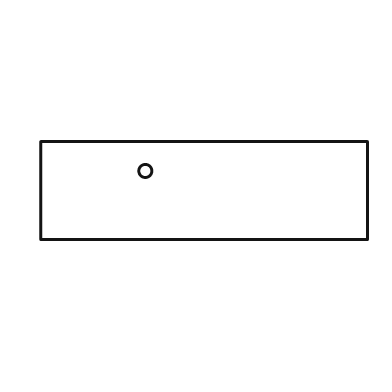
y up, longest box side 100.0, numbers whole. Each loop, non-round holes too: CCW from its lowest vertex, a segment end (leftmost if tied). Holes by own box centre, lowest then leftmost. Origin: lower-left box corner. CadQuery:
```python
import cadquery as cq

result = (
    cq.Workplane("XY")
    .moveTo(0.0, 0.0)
    .lineTo(100.0, 0.0)
    .lineTo(100.0, 30.0)
    .lineTo(0.0, 30.0)
    .close()
    .moveTo(32.0, 21.0)
    .circle(2.0)
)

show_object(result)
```